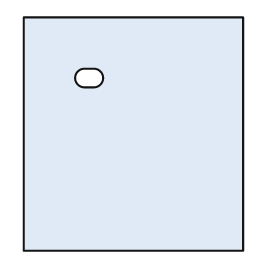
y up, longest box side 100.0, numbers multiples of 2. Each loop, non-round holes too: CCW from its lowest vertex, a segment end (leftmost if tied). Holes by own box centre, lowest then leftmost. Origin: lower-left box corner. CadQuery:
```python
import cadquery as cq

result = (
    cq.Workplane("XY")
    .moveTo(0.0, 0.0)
    .lineTo(94.0, 0.0)
    .lineTo(94.0, 100.0)
    .lineTo(0.0, 100.0)
    .close()
    .moveTo(26.0, 70.0)
    .lineTo(30.0, 70.0)
    .threePointArc((34.0, 74.0), (30.0, 78.0))
    .lineTo(26.0, 78.0)
    .threePointArc((22.0, 74.0), (26.0, 70.0))
    .close()
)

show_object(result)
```